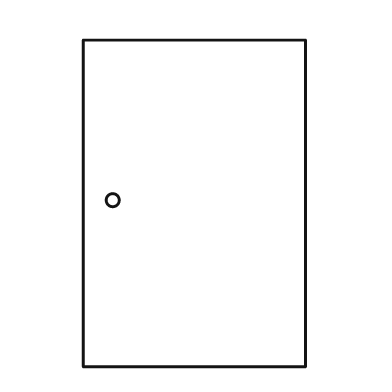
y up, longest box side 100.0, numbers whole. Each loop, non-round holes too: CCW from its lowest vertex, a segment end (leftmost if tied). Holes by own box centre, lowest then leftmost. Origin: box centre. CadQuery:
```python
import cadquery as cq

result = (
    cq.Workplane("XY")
    .moveTo(-34.0, -50.0)
    .lineTo(34.0, -50.0)
    .lineTo(34.0, 50.0)
    .lineTo(-34.0, 50.0)
    .close()
    .moveTo(-25.0, 1.0)
    .circle(2.0)
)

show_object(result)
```